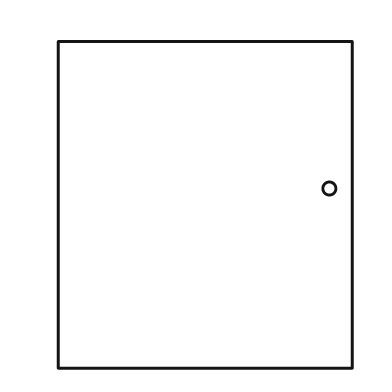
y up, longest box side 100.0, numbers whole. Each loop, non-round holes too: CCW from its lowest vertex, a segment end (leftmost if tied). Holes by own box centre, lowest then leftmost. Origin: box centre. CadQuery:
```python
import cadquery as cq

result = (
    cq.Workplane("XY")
    .moveTo(-45.0, -50.0)
    .lineTo(45.0, -50.0)
    .lineTo(45.0, 50.0)
    .lineTo(-45.0, 50.0)
    .close()
    .moveTo(38.0, 5.0)
    .circle(2.0)
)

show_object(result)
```